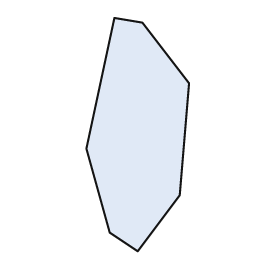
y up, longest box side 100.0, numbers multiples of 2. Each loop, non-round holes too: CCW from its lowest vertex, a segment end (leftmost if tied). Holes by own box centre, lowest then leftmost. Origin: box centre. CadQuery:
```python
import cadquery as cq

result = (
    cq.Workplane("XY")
    .moveTo(0.0, -50.0)
    .lineTo(18.0, -26.0)
    .lineTo(22.0, 22.0)
    .lineTo(2.0, 48.0)
    .lineTo(-10.0, 50.0)
    .lineTo(-22.0, -6.0)
    .lineTo(-12.0, -42.0)
    .close()
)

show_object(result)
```